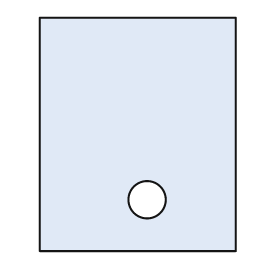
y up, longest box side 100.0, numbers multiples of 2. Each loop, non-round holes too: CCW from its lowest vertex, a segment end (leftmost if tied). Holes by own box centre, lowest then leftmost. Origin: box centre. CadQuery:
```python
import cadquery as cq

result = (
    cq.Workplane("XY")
    .moveTo(-42.0, -50.0)
    .lineTo(42.0, -50.0)
    .lineTo(42.0, 50.0)
    .lineTo(-42.0, 50.0)
    .close()
    .moveTo(4.0, -28.0)
    .circle(8.0)
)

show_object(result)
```